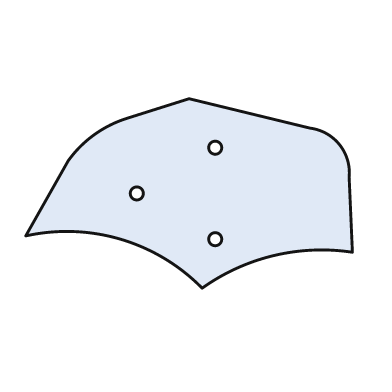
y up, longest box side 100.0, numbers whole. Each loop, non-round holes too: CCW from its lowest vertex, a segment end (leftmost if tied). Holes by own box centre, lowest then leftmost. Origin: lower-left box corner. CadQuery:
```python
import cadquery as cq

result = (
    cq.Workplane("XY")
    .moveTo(54.0, 0.0)
    .threePointArc((76.0, 10.0), (100.0, 11.0))
    .lineTo(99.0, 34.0)
    .threePointArc((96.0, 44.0), (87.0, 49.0))
    .lineTo(50.0, 58.0)
    .lineTo(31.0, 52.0)
    .threePointArc((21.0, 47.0), (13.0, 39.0))
    .lineTo(0.0, 16.0)
    .threePointArc((29.0, 15.0), (54.0, 0.0))
    .close()
    .moveTo(58.0, 15.0)
    .circle(2.0)
    .moveTo(34.0, 29.0)
    .circle(2.0)
    .moveTo(58.0, 43.0)
    .circle(2.0)
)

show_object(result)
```